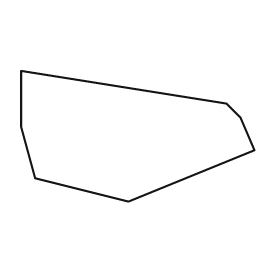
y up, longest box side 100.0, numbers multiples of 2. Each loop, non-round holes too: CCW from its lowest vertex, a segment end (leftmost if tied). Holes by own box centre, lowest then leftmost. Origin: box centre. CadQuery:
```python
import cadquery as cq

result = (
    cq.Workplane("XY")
    .moveTo(-4.0, -28.0)
    .lineTo(50.0, -6.0)
    .lineTo(44.0, 8.0)
    .lineTo(38.0, 14.0)
    .lineTo(-50.0, 28.0)
    .lineTo(-50.0, 4.0)
    .lineTo(-44.0, -18.0)
    .close()
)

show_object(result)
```